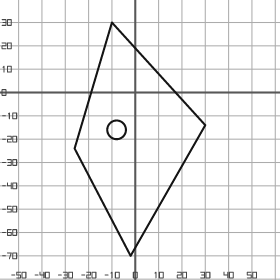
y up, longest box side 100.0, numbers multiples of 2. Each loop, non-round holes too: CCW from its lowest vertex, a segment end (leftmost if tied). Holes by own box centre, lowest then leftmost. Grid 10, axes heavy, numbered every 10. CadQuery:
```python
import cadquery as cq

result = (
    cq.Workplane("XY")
    .moveTo(-2.0, -70.0)
    .lineTo(30.0, -14.0)
    .lineTo(-10.0, 30.0)
    .lineTo(-26.0, -24.0)
    .close()
    .moveTo(-8.0, -16.0)
    .circle(4.0)
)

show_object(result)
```